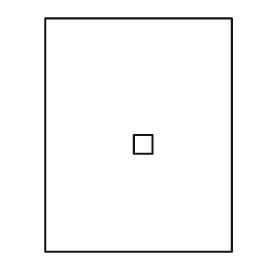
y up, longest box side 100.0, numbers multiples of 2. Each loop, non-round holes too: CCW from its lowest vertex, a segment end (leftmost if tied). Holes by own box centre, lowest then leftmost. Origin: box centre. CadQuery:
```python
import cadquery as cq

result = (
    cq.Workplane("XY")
    .moveTo(-40.0, -50.0)
    .lineTo(40.0, -50.0)
    .lineTo(40.0, 50.0)
    .lineTo(-40.0, 50.0)
    .close()
    .moveTo(-2.0, -8.0)
    .lineTo(6.0, -8.0)
    .lineTo(6.0, 0.0)
    .lineTo(-2.0, 0.0)
    .close()
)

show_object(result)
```